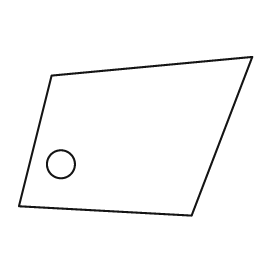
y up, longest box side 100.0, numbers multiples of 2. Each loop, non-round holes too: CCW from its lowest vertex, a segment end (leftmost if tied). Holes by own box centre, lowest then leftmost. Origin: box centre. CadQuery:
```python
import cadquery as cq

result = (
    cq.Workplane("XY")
    .moveTo(24.0, -34.0)
    .lineTo(50.0, 34.0)
    .lineTo(-36.0, 26.0)
    .lineTo(-50.0, -30.0)
    .close()
    .moveTo(-32.0, -12.0)
    .circle(6.0)
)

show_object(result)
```